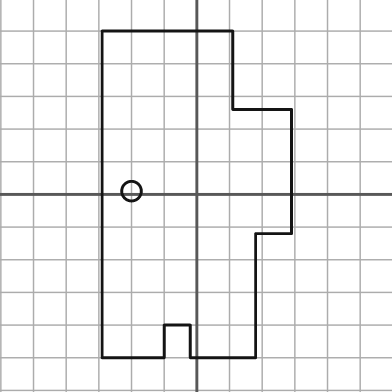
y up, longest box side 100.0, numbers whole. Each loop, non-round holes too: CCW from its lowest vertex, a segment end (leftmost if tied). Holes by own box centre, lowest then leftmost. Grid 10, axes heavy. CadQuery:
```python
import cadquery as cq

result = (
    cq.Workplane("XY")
    .moveTo(-29.0, -50.0)
    .lineTo(-10.0, -50.0)
    .lineTo(-10.0, -40.0)
    .lineTo(-2.0, -40.0)
    .lineTo(-2.0, -50.0)
    .lineTo(18.0, -50.0)
    .lineTo(18.0, -12.0)
    .lineTo(29.0, -12.0)
    .lineTo(29.0, 26.0)
    .lineTo(11.0, 26.0)
    .lineTo(11.0, 50.0)
    .lineTo(-29.0, 50.0)
    .close()
    .moveTo(-20.0, 1.0)
    .circle(3.0)
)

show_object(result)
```